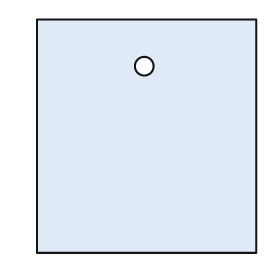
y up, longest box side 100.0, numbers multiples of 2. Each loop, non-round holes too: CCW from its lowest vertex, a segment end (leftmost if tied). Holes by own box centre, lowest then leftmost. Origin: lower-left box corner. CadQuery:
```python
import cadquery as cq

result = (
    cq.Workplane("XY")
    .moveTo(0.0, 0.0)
    .lineTo(94.0, 0.0)
    .lineTo(94.0, 100.0)
    .lineTo(0.0, 100.0)
    .close()
    .moveTo(46.0, 80.0)
    .circle(4.0)
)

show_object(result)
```